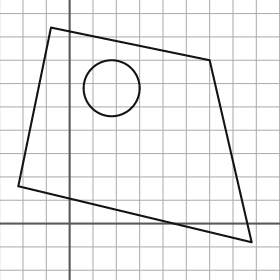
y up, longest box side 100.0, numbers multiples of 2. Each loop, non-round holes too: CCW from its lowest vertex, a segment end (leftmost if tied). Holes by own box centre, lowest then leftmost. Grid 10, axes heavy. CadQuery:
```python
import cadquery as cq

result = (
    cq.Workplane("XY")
    .moveTo(78.0, -8.0)
    .lineTo(60.0, 70.0)
    .lineTo(-8.0, 84.0)
    .lineTo(-22.0, 16.0)
    .close()
    .moveTo(18.0, 58.0)
    .circle(12.0)
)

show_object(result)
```